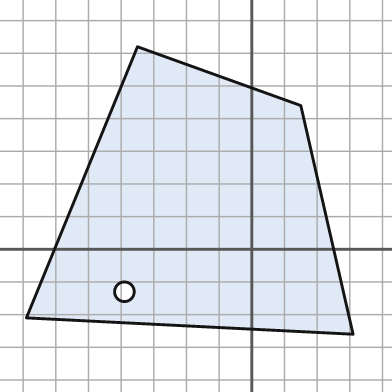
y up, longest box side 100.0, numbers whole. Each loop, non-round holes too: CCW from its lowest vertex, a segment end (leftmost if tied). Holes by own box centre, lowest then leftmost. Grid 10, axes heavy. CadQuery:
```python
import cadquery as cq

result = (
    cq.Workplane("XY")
    .moveTo(31.0, -26.0)
    .lineTo(15.0, 44.0)
    .lineTo(-35.0, 62.0)
    .lineTo(-69.0, -21.0)
    .close()
    .moveTo(-39.0, -13.0)
    .circle(3.0)
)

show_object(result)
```